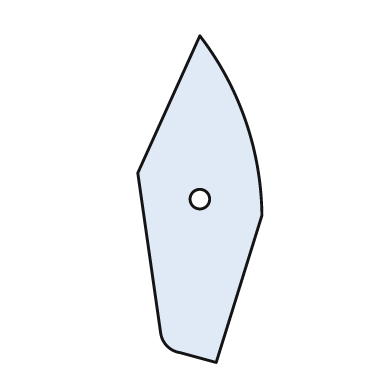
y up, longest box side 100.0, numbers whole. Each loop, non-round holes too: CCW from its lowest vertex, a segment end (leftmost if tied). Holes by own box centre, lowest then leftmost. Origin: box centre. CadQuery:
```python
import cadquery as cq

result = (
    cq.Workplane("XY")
    .moveTo(5.0, -50.0)
    .lineTo(19.0, -5.0)
    .threePointArc((14.0, 24.0), (0.0, 50.0))
    .lineTo(-19.0, 8.0)
    .lineTo(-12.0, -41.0)
    .threePointArc((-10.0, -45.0), (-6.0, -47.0))
    .close()
    .moveTo(0.0, 0.0)
    .circle(3.0)
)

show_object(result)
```